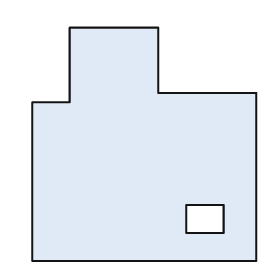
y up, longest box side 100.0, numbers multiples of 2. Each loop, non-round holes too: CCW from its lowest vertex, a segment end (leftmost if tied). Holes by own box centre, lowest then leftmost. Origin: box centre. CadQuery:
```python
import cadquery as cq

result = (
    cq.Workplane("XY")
    .moveTo(-48.0, -50.0)
    .lineTo(48.0, -50.0)
    .lineTo(48.0, 22.0)
    .lineTo(6.0, 22.0)
    .lineTo(6.0, 50.0)
    .lineTo(-32.0, 50.0)
    .lineTo(-32.0, 18.0)
    .lineTo(-48.0, 18.0)
    .close()
    .moveTo(18.0, -38.0)
    .lineTo(34.0, -38.0)
    .lineTo(34.0, -26.0)
    .lineTo(18.0, -26.0)
    .close()
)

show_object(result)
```